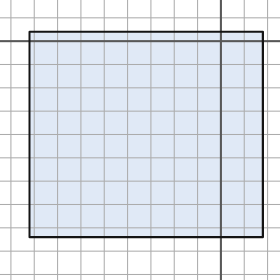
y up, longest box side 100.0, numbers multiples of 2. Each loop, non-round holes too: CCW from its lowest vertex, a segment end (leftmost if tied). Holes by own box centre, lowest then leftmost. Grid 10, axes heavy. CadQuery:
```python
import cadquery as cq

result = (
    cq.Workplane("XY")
    .moveTo(-82.0, -84.0)
    .lineTo(18.0, -84.0)
    .lineTo(18.0, 4.0)
    .lineTo(-82.0, 4.0)
    .close()
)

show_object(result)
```